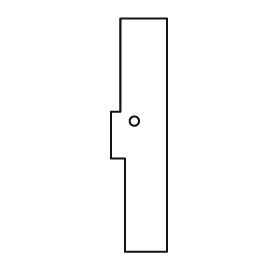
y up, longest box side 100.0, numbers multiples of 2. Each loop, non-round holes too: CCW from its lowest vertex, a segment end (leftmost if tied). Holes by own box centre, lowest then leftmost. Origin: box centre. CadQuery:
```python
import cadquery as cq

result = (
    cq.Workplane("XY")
    .moveTo(-6.0, -50.0)
    .lineTo(12.0, -50.0)
    .lineTo(12.0, 50.0)
    .lineTo(-8.0, 50.0)
    .lineTo(-8.0, 10.0)
    .lineTo(-12.0, 10.0)
    .lineTo(-12.0, -10.0)
    .lineTo(-6.0, -10.0)
    .close()
    .moveTo(-2.0, 6.0)
    .circle(2.0)
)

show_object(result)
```